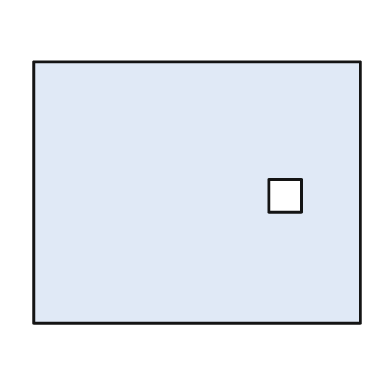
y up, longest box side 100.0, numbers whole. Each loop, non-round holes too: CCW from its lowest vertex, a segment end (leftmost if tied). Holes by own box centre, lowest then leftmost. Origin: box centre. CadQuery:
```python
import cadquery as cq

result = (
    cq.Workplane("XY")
    .moveTo(-50.0, -40.0)
    .lineTo(50.0, -40.0)
    .lineTo(50.0, 40.0)
    .lineTo(-50.0, 40.0)
    .close()
    .moveTo(22.0, -6.0)
    .lineTo(32.0, -6.0)
    .lineTo(32.0, 4.0)
    .lineTo(22.0, 4.0)
    .close()
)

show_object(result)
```